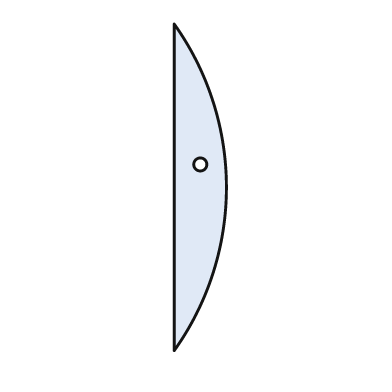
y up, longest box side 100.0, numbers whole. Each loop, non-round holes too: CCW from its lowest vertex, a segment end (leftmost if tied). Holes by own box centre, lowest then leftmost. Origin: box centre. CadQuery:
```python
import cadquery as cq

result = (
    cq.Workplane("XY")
    .moveTo(-8.0, -50.0)
    .threePointArc((8.0, 0.0), (-8.0, 50.0))
    .close()
    .moveTo(0.0, 7.0)
    .circle(2.0)
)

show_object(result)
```